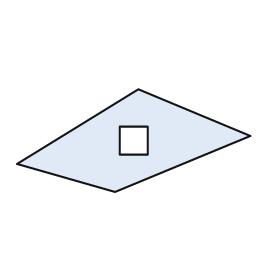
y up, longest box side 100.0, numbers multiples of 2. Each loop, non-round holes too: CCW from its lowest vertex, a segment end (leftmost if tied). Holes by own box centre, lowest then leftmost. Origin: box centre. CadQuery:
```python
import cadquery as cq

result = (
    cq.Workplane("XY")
    .moveTo(-8.0, -22.0)
    .lineTo(50.0, 2.0)
    .lineTo(2.0, 22.0)
    .lineTo(-50.0, -10.0)
    .close()
    .moveTo(-6.0, -6.0)
    .lineTo(6.0, -6.0)
    .lineTo(6.0, 6.0)
    .lineTo(-6.0, 6.0)
    .close()
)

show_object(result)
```